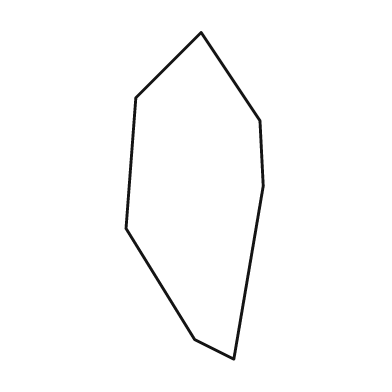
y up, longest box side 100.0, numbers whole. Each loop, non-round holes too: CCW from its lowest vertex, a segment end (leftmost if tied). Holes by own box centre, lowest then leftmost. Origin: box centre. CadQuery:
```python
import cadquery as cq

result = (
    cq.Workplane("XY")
    .moveTo(12.0, -50.0)
    .lineTo(21.0, 3.0)
    .lineTo(20.0, 23.0)
    .lineTo(2.0, 50.0)
    .lineTo(-18.0, 30.0)
    .lineTo(-21.0, -10.0)
    .lineTo(0.0, -44.0)
    .close()
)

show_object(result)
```